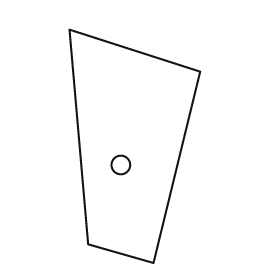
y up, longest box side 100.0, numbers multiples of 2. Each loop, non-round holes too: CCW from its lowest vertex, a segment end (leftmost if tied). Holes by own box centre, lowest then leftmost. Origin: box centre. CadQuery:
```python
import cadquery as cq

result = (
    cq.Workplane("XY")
    .moveTo(8.0, -50.0)
    .lineTo(28.0, 32.0)
    .lineTo(-28.0, 50.0)
    .lineTo(-20.0, -42.0)
    .close()
    .moveTo(-6.0, -8.0)
    .circle(4.0)
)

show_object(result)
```